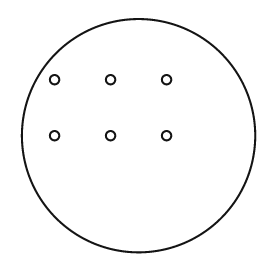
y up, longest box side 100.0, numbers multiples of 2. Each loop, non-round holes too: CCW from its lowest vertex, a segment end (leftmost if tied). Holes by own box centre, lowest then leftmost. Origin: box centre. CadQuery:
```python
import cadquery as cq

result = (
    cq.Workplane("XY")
    .moveTo(0.0, 0.0)
    .circle(50.0)
    .moveTo(-36.0, 0.0)
    .circle(2.0)
    .moveTo(-12.0, 0.0)
    .circle(2.0)
    .moveTo(12.0, 0.0)
    .circle(2.0)
    .moveTo(-36.0, 24.0)
    .circle(2.0)
    .moveTo(-12.0, 24.0)
    .circle(2.0)
    .moveTo(12.0, 24.0)
    .circle(2.0)
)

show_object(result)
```